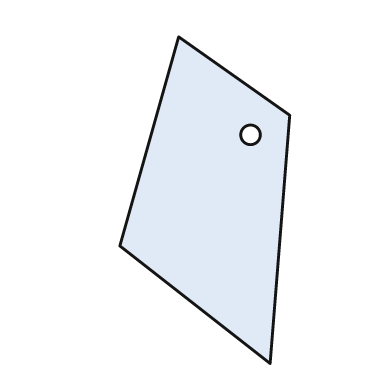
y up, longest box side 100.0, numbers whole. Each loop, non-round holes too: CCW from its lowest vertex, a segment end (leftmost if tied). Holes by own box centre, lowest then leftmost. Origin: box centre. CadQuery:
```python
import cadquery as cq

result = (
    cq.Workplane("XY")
    .moveTo(20.0, -50.0)
    .lineTo(26.0, 26.0)
    .lineTo(-8.0, 50.0)
    .lineTo(-26.0, -14.0)
    .close()
    .moveTo(14.0, 20.0)
    .circle(3.0)
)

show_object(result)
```